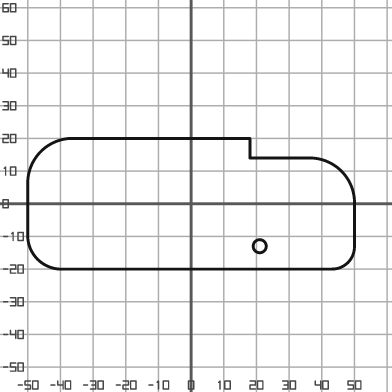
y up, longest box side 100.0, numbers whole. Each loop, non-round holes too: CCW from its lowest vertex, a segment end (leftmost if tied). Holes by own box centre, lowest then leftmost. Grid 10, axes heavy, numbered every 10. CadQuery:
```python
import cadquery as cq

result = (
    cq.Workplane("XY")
    .moveTo(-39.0, -20.0)
    .lineTo(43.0, -20.0)
    .threePointArc((48.0, -18.0), (50.0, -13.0))
    .lineTo(50.0, 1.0)
    .threePointArc((46.0, 10.0), (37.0, 14.0))
    .lineTo(18.0, 14.0)
    .lineTo(18.0, 20.0)
    .lineTo(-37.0, 20.0)
    .threePointArc((-46.0, 16.0), (-50.0, 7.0))
    .lineTo(-50.0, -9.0)
    .threePointArc((-47.0, -17.0), (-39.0, -20.0))
    .close()
    .moveTo(21.0, -13.0)
    .circle(2.0)
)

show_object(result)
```